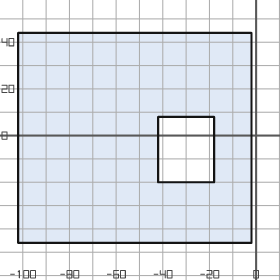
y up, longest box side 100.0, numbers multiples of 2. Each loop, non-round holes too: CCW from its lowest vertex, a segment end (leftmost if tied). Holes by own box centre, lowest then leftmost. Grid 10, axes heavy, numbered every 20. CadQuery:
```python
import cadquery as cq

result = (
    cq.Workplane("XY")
    .moveTo(-102.0, -46.0)
    .lineTo(-2.0, -46.0)
    .lineTo(-2.0, 44.0)
    .lineTo(-102.0, 44.0)
    .close()
    .moveTo(-42.0, -20.0)
    .lineTo(-18.0, -20.0)
    .lineTo(-18.0, 8.0)
    .lineTo(-42.0, 8.0)
    .close()
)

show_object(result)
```